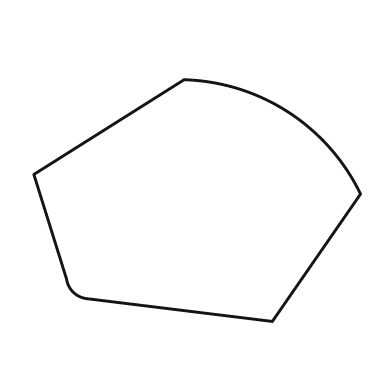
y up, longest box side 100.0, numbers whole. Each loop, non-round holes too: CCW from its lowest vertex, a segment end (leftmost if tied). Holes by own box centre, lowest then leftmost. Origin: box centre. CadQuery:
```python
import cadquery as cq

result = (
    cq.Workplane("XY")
    .moveTo(23.0, -37.0)
    .lineTo(50.0, 2.0)
    .threePointArc((28.0, 27.0), (-4.0, 37.0))
    .lineTo(-50.0, 8.0)
    .lineTo(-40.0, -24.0)
    .threePointArc((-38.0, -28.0), (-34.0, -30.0))
    .close()
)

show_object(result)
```